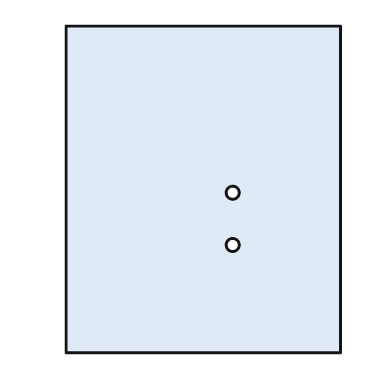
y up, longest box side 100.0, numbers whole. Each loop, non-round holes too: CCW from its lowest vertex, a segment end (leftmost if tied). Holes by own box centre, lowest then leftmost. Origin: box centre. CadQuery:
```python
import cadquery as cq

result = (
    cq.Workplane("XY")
    .moveTo(-42.0, -50.0)
    .lineTo(42.0, -50.0)
    .lineTo(42.0, 50.0)
    .lineTo(-42.0, 50.0)
    .close()
    .moveTo(9.0, -17.0)
    .circle(2.0)
    .moveTo(9.0, -1.0)
    .circle(2.0)
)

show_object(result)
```